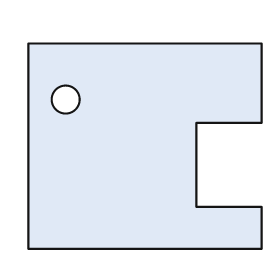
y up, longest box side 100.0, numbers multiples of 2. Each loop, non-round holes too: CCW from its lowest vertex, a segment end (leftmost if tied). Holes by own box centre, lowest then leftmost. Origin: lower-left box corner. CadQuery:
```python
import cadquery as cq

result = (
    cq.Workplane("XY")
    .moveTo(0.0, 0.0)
    .lineTo(100.0, 0.0)
    .lineTo(100.0, 18.0)
    .lineTo(72.0, 18.0)
    .lineTo(72.0, 54.0)
    .lineTo(100.0, 54.0)
    .lineTo(100.0, 88.0)
    .lineTo(0.0, 88.0)
    .close()
    .moveTo(16.0, 64.0)
    .circle(6.0)
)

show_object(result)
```